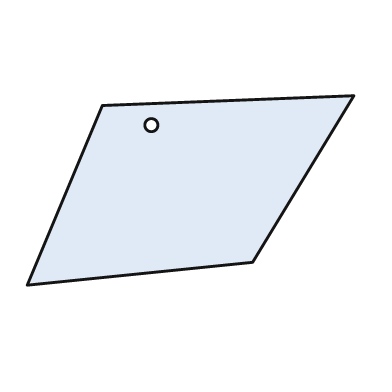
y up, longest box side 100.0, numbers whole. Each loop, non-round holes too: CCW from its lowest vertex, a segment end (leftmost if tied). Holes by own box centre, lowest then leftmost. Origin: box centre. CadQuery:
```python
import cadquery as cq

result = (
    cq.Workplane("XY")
    .moveTo(-50.0, -29.0)
    .lineTo(19.0, -22.0)
    .lineTo(50.0, 29.0)
    .lineTo(-27.0, 26.0)
    .close()
    .moveTo(-12.0, 20.0)
    .circle(2.0)
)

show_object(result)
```